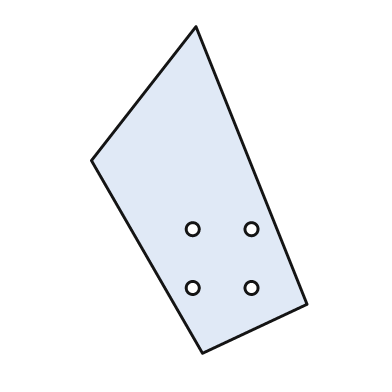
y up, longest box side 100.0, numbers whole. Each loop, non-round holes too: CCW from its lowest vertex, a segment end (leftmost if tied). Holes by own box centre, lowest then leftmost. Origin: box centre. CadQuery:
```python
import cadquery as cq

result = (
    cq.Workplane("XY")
    .moveTo(1.0, -50.0)
    .lineTo(33.0, -35.0)
    .lineTo(-1.0, 50.0)
    .lineTo(-33.0, 9.0)
    .close()
    .moveTo(-2.0, -30.0)
    .circle(2.0)
    .moveTo(16.0, -30.0)
    .circle(2.0)
    .moveTo(-2.0, -12.0)
    .circle(2.0)
    .moveTo(16.0, -12.0)
    .circle(2.0)
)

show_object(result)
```